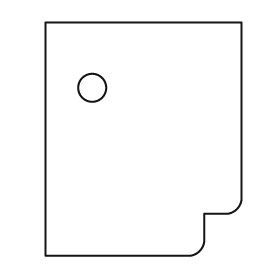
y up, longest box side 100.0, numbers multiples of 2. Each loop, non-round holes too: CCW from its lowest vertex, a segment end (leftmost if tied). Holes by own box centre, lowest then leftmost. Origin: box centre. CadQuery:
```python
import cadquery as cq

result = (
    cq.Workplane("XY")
    .moveTo(-42.0, -50.0)
    .lineTo(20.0, -50.0)
    .threePointArc((24.0, -48.0), (26.0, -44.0))
    .lineTo(26.0, -32.0)
    .lineTo(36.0, -32.0)
    .threePointArc((40.0, -30.0), (42.0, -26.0))
    .lineTo(42.0, 50.0)
    .lineTo(-42.0, 50.0)
    .close()
    .moveTo(-22.0, 22.0)
    .circle(6.0)
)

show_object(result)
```